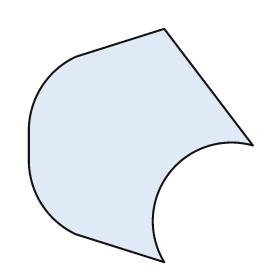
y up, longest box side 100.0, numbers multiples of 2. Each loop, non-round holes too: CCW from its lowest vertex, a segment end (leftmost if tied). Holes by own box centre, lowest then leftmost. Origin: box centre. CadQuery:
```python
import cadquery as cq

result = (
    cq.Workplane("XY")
    .moveTo(10.0, -50.0)
    .threePointArc((12.0, -12.0), (48.0, 0.0))
    .lineTo(10.0, 50.0)
    .lineTo(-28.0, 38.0)
    .threePointArc((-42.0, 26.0), (-48.0, 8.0))
    .lineTo(-48.0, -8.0)
    .threePointArc((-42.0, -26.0), (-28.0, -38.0))
    .close()
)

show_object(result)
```